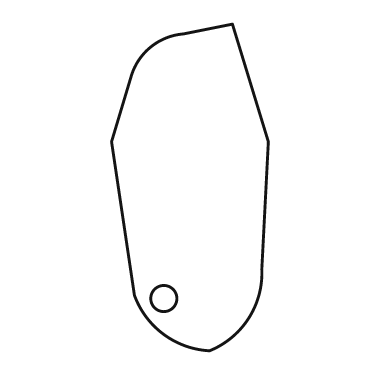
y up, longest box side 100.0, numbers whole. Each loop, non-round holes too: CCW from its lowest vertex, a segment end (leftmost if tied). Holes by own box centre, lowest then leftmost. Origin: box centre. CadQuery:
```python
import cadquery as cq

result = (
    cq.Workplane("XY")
    .moveTo(6.0, -50.0)
    .threePointArc((18.0, -40.0), (22.0, -25.0))
    .lineTo(24.0, 14.0)
    .lineTo(13.0, 50.0)
    .lineTo(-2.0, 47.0)
    .threePointArc((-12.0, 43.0), (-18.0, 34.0))
    .lineTo(-24.0, 14.0)
    .lineTo(-17.0, -33.0)
    .threePointArc((-8.0, -45.0), (6.0, -50.0))
    .close()
    .moveTo(-8.0, -34.0)
    .circle(4.0)
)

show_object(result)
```